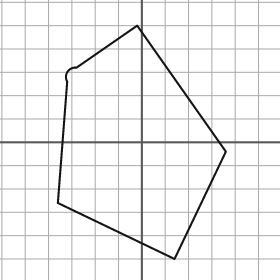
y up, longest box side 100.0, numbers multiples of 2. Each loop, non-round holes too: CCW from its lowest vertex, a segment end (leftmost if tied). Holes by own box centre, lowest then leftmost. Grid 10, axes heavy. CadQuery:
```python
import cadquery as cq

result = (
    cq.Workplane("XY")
    .moveTo(14.0, -50.0)
    .lineTo(36.0, -4.0)
    .lineTo(-2.0, 50.0)
    .lineTo(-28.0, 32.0)
    .threePointArc((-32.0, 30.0), (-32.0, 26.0))
    .lineTo(-36.0, -26.0)
    .close()
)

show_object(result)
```